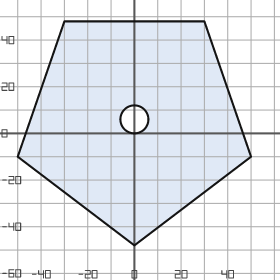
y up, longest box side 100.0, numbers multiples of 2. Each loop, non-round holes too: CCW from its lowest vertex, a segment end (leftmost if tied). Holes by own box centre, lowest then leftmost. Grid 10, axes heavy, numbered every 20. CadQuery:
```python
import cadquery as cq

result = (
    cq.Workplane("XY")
    .moveTo(0.0, -48.0)
    .lineTo(50.0, -10.0)
    .lineTo(30.0, 48.0)
    .lineTo(-30.0, 48.0)
    .lineTo(-50.0, -10.0)
    .close()
    .moveTo(0.0, 6.0)
    .circle(6.0)
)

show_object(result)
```